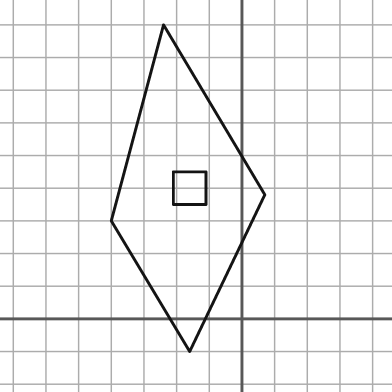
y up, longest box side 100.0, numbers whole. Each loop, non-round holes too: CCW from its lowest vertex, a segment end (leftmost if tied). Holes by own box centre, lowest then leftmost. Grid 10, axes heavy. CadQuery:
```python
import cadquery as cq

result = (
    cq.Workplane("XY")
    .moveTo(-16.0, -10.0)
    .lineTo(7.0, 38.0)
    .lineTo(-24.0, 90.0)
    .lineTo(-40.0, 30.0)
    .close()
    .moveTo(-21.0, 35.0)
    .lineTo(-11.0, 35.0)
    .lineTo(-11.0, 45.0)
    .lineTo(-21.0, 45.0)
    .close()
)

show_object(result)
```